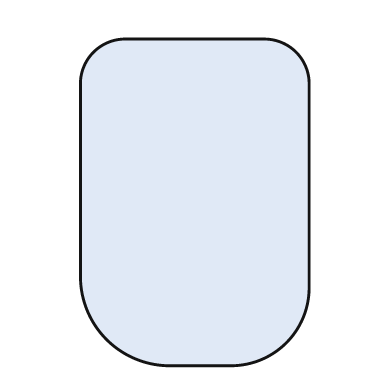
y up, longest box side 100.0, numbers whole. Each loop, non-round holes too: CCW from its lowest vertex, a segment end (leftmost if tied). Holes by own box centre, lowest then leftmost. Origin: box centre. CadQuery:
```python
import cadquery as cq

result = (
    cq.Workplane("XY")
    .moveTo(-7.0, -50.0)
    .lineTo(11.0, -50.0)
    .threePointArc((28.0, -43.0), (35.0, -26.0))
    .lineTo(35.0, 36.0)
    .threePointArc((31.0, 46.0), (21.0, 50.0))
    .lineTo(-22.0, 50.0)
    .threePointArc((-31.0, 46.0), (-35.0, 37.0))
    .lineTo(-35.0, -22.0)
    .threePointArc((-27.0, -42.0), (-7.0, -50.0))
    .close()
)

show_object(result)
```